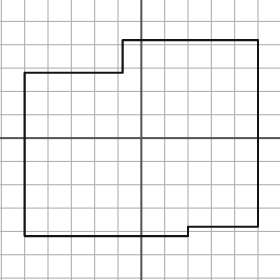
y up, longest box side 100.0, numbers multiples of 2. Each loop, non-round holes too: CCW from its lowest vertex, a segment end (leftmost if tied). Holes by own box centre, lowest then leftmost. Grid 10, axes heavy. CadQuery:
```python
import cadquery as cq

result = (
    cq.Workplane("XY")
    .moveTo(-50.0, -42.0)
    .lineTo(20.0, -42.0)
    .lineTo(20.0, -38.0)
    .lineTo(50.0, -38.0)
    .lineTo(50.0, 42.0)
    .lineTo(-8.0, 42.0)
    .lineTo(-8.0, 28.0)
    .lineTo(-50.0, 28.0)
    .close()
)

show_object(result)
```